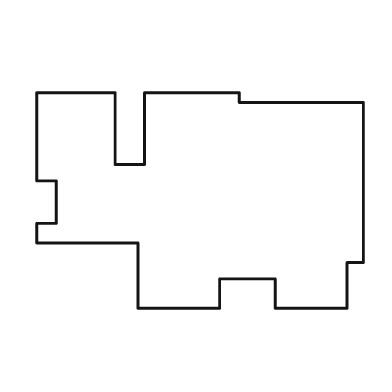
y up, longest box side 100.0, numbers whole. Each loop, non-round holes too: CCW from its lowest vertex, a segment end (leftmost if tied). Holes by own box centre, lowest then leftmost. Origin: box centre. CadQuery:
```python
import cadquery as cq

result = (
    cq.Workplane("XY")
    .moveTo(-19.0, -33.0)
    .lineTo(6.0, -33.0)
    .lineTo(6.0, -24.0)
    .lineTo(23.0, -24.0)
    .lineTo(23.0, -33.0)
    .lineTo(45.0, -33.0)
    .lineTo(45.0, -19.0)
    .lineTo(50.0, -19.0)
    .lineTo(50.0, 30.0)
    .lineTo(12.0, 30.0)
    .lineTo(12.0, 33.0)
    .lineTo(-17.0, 33.0)
    .lineTo(-17.0, 11.0)
    .lineTo(-26.0, 11.0)
    .lineTo(-26.0, 33.0)
    .lineTo(-50.0, 33.0)
    .lineTo(-50.0, 6.0)
    .lineTo(-44.0, 6.0)
    .lineTo(-44.0, -7.0)
    .lineTo(-50.0, -7.0)
    .lineTo(-50.0, -13.0)
    .lineTo(-19.0, -13.0)
    .close()
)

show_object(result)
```